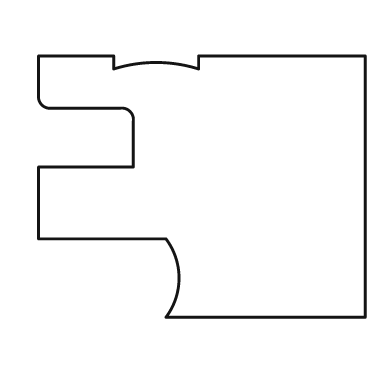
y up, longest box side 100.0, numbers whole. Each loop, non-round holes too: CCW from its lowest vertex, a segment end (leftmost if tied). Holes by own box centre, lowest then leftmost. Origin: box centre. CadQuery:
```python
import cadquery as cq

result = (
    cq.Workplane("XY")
    .moveTo(-11.0, -40.0)
    .lineTo(50.0, -40.0)
    .lineTo(50.0, 40.0)
    .lineTo(-1.0, 40.0)
    .lineTo(-1.0, 36.0)
    .threePointArc((-14.0, 38.0), (-27.0, 36.0))
    .lineTo(-27.0, 40.0)
    .lineTo(-50.0, 40.0)
    .lineTo(-50.0, 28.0)
    .threePointArc((-49.0, 25.0), (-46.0, 24.0))
    .lineTo(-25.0, 24.0)
    .threePointArc((-22.0, 23.0), (-21.0, 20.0))
    .lineTo(-21.0, 6.0)
    .lineTo(-50.0, 6.0)
    .lineTo(-50.0, -16.0)
    .lineTo(-11.0, -16.0)
    .threePointArc((-7.0, -28.0), (-11.0, -40.0))
    .close()
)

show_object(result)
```